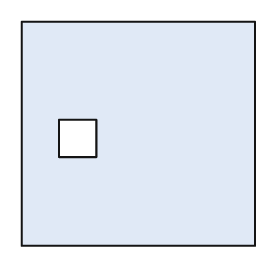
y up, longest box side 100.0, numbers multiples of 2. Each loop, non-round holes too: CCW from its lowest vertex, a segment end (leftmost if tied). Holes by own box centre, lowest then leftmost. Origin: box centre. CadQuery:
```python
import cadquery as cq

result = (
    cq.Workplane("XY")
    .moveTo(-50.0, -48.0)
    .lineTo(50.0, -48.0)
    .lineTo(50.0, 48.0)
    .lineTo(-50.0, 48.0)
    .close()
    .moveTo(-34.0, -10.0)
    .lineTo(-18.0, -10.0)
    .lineTo(-18.0, 6.0)
    .lineTo(-34.0, 6.0)
    .close()
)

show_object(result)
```